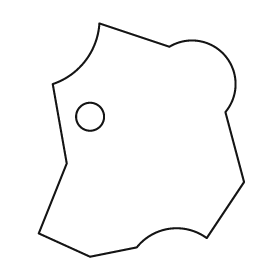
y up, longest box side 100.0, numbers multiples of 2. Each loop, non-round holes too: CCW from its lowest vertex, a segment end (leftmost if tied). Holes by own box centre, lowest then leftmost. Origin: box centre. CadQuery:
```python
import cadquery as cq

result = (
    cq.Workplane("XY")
    .moveTo(-22.0, -50.0)
    .lineTo(-2.0, -46.0)
    .threePointArc((12.0, -38.0), (28.0, -42.0))
    .lineTo(44.0, -18.0)
    .lineTo(36.0, 12.0)
    .threePointArc((36.0, 36.0), (12.0, 40.0))
    .lineTo(-18.0, 50.0)
    .threePointArc((-24.0, 34.0), (-38.0, 24.0))
    .lineTo(-32.0, -10.0)
    .lineTo(-44.0, -40.0)
    .close()
    .moveTo(-22.0, 10.0)
    .circle(6.0)
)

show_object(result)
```